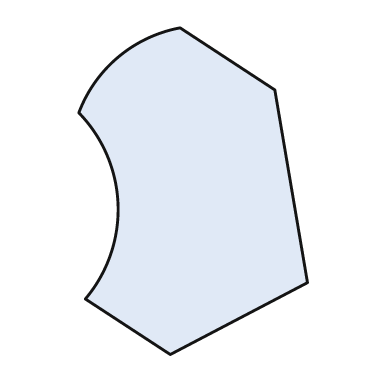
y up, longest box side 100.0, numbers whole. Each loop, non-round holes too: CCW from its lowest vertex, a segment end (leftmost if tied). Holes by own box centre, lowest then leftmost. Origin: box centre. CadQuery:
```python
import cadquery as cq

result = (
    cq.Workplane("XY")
    .moveTo(-7.0, -50.0)
    .lineTo(35.0, -28.0)
    .lineTo(25.0, 31.0)
    .lineTo(-4.0, 50.0)
    .threePointArc((-23.0, 41.0), (-35.0, 24.0))
    .threePointArc((-23.0, -4.0), (-33.0, -33.0))
    .close()
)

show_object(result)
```